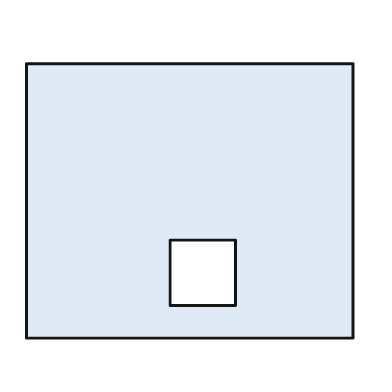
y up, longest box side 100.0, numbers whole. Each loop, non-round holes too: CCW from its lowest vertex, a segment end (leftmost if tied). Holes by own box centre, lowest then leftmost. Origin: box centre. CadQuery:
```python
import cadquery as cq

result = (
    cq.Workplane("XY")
    .moveTo(-50.0, -42.0)
    .lineTo(50.0, -42.0)
    .lineTo(50.0, 42.0)
    .lineTo(-50.0, 42.0)
    .close()
    .moveTo(-6.0, -32.0)
    .lineTo(14.0, -32.0)
    .lineTo(14.0, -12.0)
    .lineTo(-6.0, -12.0)
    .close()
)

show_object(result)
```